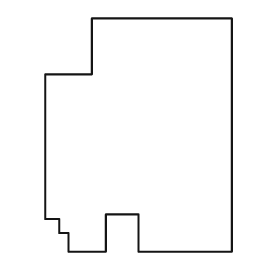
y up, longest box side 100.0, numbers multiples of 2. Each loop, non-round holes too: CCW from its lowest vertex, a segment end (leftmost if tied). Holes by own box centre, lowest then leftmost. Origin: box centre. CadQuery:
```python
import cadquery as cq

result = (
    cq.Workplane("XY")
    .moveTo(-30.0, -50.0)
    .lineTo(-14.0, -50.0)
    .lineTo(-14.0, -34.0)
    .lineTo(0.0, -34.0)
    .lineTo(0.0, -50.0)
    .lineTo(40.0, -50.0)
    .lineTo(40.0, 50.0)
    .lineTo(-20.0, 50.0)
    .lineTo(-20.0, 26.0)
    .lineTo(-40.0, 26.0)
    .lineTo(-40.0, -36.0)
    .lineTo(-34.0, -36.0)
    .lineTo(-34.0, -42.0)
    .lineTo(-30.0, -42.0)
    .close()
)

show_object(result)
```